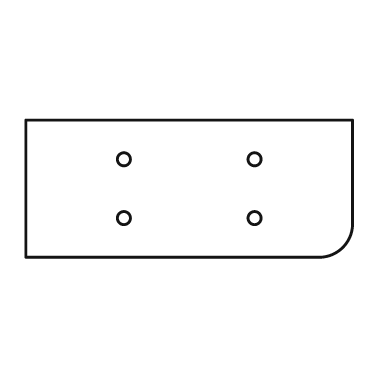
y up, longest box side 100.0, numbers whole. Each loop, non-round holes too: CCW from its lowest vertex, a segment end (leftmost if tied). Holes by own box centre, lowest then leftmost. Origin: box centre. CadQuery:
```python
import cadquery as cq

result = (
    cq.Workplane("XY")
    .moveTo(-50.0, -21.0)
    .lineTo(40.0, -21.0)
    .threePointArc((47.0, -18.0), (50.0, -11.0))
    .lineTo(50.0, 21.0)
    .lineTo(-50.0, 21.0)
    .close()
    .moveTo(-20.0, -9.0)
    .circle(2.0)
    .moveTo(20.0, -9.0)
    .circle(2.0)
    .moveTo(-20.0, 9.0)
    .circle(2.0)
    .moveTo(20.0, 9.0)
    .circle(2.0)
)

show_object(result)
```